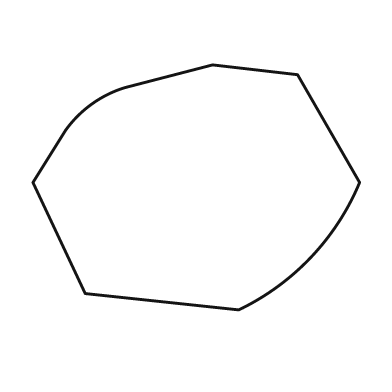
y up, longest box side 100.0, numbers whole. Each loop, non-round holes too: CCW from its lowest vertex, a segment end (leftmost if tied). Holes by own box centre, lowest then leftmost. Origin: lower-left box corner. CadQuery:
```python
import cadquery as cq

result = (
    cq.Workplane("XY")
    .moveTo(63.0, 0.0)
    .threePointArc((85.0, 16.0), (100.0, 39.0))
    .lineTo(81.0, 72.0)
    .lineTo(55.0, 75.0)
    .lineTo(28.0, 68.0)
    .threePointArc((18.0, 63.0), (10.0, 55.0))
    .lineTo(0.0, 39.0)
    .lineTo(16.0, 5.0)
    .close()
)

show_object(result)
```